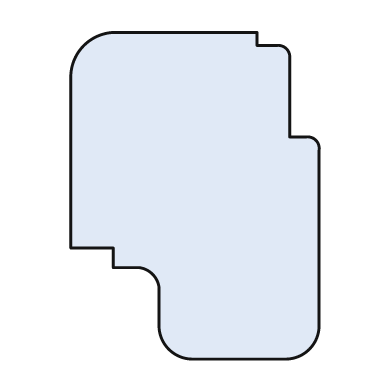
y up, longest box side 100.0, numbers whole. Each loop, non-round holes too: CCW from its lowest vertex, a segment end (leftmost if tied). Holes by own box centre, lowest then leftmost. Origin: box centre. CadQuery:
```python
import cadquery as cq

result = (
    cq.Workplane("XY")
    .moveTo(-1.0, -50.0)
    .lineTo(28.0, -50.0)
    .threePointArc((35.0, -47.0), (38.0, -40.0))
    .lineTo(38.0, 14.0)
    .threePointArc((37.0, 17.0), (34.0, 18.0))
    .lineTo(29.0, 18.0)
    .lineTo(29.0, 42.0)
    .threePointArc((28.0, 45.0), (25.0, 46.0))
    .lineTo(19.0, 46.0)
    .lineTo(19.0, 50.0)
    .lineTo(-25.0, 50.0)
    .threePointArc((-34.0, 46.0), (-38.0, 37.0))
    .lineTo(-38.0, -16.0)
    .lineTo(-25.0, -16.0)
    .lineTo(-25.0, -22.0)
    .lineTo(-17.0, -22.0)
    .threePointArc((-13.0, -24.0), (-11.0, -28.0))
    .lineTo(-11.0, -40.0)
    .threePointArc((-8.0, -47.0), (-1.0, -50.0))
    .close()
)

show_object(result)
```